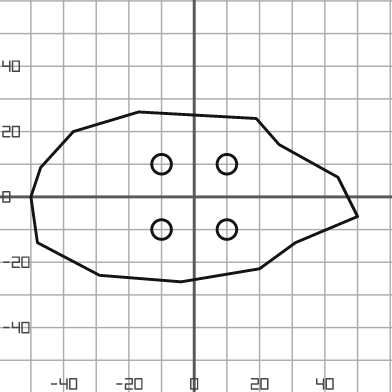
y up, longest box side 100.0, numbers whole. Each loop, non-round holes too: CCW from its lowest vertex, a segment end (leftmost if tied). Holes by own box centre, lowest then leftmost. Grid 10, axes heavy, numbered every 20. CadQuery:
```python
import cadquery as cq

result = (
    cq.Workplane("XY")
    .moveTo(-4.0, -26.0)
    .lineTo(20.0, -22.0)
    .lineTo(31.0, -14.0)
    .lineTo(50.0, -6.0)
    .lineTo(44.0, 6.0)
    .lineTo(26.0, 16.0)
    .lineTo(19.0, 24.0)
    .lineTo(-17.0, 26.0)
    .lineTo(-37.0, 20.0)
    .lineTo(-47.0, 9.0)
    .lineTo(-50.0, 0.0)
    .lineTo(-48.0, -14.0)
    .lineTo(-29.0, -24.0)
    .close()
    .moveTo(-10.0, -10.0)
    .circle(3.0)
    .moveTo(10.0, -10.0)
    .circle(3.0)
    .moveTo(-10.0, 10.0)
    .circle(3.0)
    .moveTo(10.0, 10.0)
    .circle(3.0)
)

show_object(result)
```